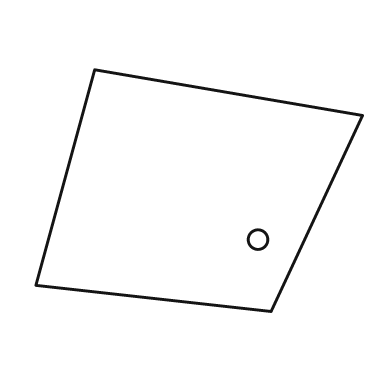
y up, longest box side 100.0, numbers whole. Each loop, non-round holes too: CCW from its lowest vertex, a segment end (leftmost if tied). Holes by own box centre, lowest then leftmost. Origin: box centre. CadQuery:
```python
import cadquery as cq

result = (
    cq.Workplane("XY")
    .moveTo(22.0, -37.0)
    .lineTo(50.0, 23.0)
    .lineTo(-32.0, 37.0)
    .lineTo(-50.0, -29.0)
    .close()
    .moveTo(18.0, -15.0)
    .circle(3.0)
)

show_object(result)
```